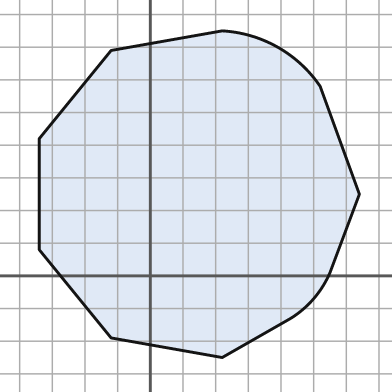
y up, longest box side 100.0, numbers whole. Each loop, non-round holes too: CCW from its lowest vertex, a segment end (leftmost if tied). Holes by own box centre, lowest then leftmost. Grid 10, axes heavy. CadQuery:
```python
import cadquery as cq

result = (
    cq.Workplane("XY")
    .moveTo(22.0, -25.0)
    .lineTo(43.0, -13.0)
    .threePointArc((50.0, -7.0), (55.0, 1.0))
    .lineTo(64.0, 25.0)
    .lineTo(52.0, 58.0)
    .threePointArc((39.0, 70.0), (22.0, 75.0))
    .lineTo(-12.0, 69.0)
    .lineTo(-34.0, 42.0)
    .lineTo(-34.0, 8.0)
    .lineTo(-12.0, -19.0)
    .close()
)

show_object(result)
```